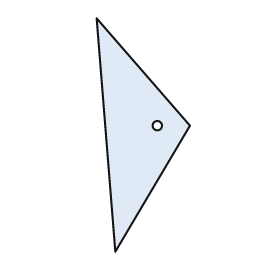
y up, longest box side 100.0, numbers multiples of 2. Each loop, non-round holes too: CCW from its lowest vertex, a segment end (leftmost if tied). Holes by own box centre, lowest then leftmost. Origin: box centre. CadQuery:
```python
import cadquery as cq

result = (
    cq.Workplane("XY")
    .moveTo(-12.0, -50.0)
    .lineTo(20.0, 4.0)
    .lineTo(-20.0, 50.0)
    .close()
    .moveTo(6.0, 4.0)
    .circle(2.0)
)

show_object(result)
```